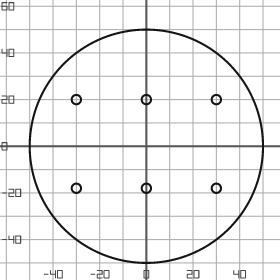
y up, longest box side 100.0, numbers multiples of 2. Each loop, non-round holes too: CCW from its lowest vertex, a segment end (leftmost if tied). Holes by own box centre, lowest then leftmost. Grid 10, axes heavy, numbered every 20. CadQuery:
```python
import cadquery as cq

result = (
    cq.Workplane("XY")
    .moveTo(0.0, 0.0)
    .circle(50.0)
    .moveTo(-30.0, -18.0)
    .circle(2.0)
    .moveTo(0.0, -18.0)
    .circle(2.0)
    .moveTo(30.0, -18.0)
    .circle(2.0)
    .moveTo(-30.0, 20.0)
    .circle(2.0)
    .moveTo(0.0, 20.0)
    .circle(2.0)
    .moveTo(30.0, 20.0)
    .circle(2.0)
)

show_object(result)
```